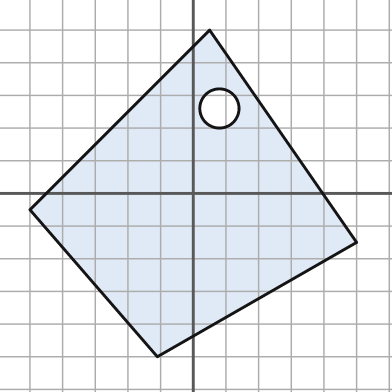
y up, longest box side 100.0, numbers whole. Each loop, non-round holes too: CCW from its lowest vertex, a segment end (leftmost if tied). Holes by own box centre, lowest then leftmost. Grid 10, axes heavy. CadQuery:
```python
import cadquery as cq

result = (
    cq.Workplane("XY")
    .moveTo(-11.0, -50.0)
    .lineTo(50.0, -15.0)
    .lineTo(5.0, 50.0)
    .lineTo(-50.0, -5.0)
    .close()
    .moveTo(8.0, 26.0)
    .circle(6.0)
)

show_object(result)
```